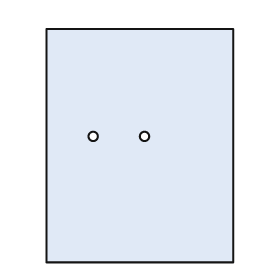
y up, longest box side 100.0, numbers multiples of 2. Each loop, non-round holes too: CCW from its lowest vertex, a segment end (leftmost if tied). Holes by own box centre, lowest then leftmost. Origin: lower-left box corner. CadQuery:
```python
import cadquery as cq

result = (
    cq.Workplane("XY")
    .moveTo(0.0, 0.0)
    .lineTo(80.0, 0.0)
    .lineTo(80.0, 100.0)
    .lineTo(0.0, 100.0)
    .close()
    .moveTo(20.0, 54.0)
    .circle(2.0)
    .moveTo(42.0, 54.0)
    .circle(2.0)
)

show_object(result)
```